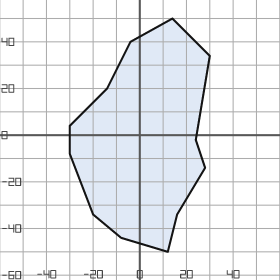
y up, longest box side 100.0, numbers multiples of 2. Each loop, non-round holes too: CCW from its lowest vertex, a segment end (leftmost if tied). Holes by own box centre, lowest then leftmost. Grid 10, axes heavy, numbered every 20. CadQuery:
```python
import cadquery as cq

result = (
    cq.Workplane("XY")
    .moveTo(12.0, -50.0)
    .lineTo(16.0, -34.0)
    .lineTo(28.0, -14.0)
    .lineTo(24.0, -2.0)
    .lineTo(30.0, 34.0)
    .lineTo(14.0, 50.0)
    .lineTo(-4.0, 40.0)
    .lineTo(-14.0, 20.0)
    .lineTo(-30.0, 4.0)
    .lineTo(-30.0, -8.0)
    .lineTo(-20.0, -34.0)
    .lineTo(-8.0, -44.0)
    .close()
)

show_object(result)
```